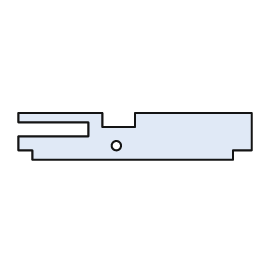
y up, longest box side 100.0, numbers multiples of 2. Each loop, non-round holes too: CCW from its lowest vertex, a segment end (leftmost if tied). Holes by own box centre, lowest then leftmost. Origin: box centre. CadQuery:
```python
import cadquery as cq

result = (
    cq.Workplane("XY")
    .moveTo(-44.0, -10.0)
    .lineTo(42.0, -10.0)
    .lineTo(42.0, -6.0)
    .lineTo(50.0, -6.0)
    .lineTo(50.0, 10.0)
    .lineTo(0.0, 10.0)
    .lineTo(0.0, 4.0)
    .lineTo(-14.0, 4.0)
    .lineTo(-14.0, 10.0)
    .lineTo(-50.0, 10.0)
    .lineTo(-50.0, 6.0)
    .lineTo(-20.0, 6.0)
    .lineTo(-20.0, 0.0)
    .lineTo(-50.0, 0.0)
    .lineTo(-50.0, -6.0)
    .lineTo(-44.0, -6.0)
    .close()
    .moveTo(-8.0, -4.0)
    .circle(2.0)
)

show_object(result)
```